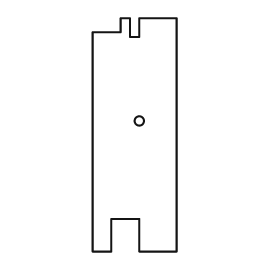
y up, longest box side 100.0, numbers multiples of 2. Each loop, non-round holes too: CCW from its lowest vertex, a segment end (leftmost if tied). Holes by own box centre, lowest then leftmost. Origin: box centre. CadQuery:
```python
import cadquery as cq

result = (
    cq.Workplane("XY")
    .moveTo(-18.0, -50.0)
    .lineTo(-10.0, -50.0)
    .lineTo(-10.0, -36.0)
    .lineTo(2.0, -36.0)
    .lineTo(2.0, -50.0)
    .lineTo(18.0, -50.0)
    .lineTo(18.0, 50.0)
    .lineTo(2.0, 50.0)
    .lineTo(2.0, 42.0)
    .lineTo(-2.0, 42.0)
    .lineTo(-2.0, 50.0)
    .lineTo(-6.0, 50.0)
    .lineTo(-6.0, 44.0)
    .lineTo(-18.0, 44.0)
    .close()
    .moveTo(2.0, 6.0)
    .circle(2.0)
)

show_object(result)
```